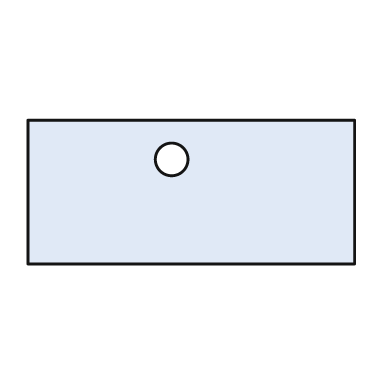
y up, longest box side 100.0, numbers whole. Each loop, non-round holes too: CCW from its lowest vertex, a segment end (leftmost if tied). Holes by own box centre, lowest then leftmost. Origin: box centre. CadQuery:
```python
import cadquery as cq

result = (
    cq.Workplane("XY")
    .moveTo(-50.0, -22.0)
    .lineTo(50.0, -22.0)
    .lineTo(50.0, 22.0)
    .lineTo(-50.0, 22.0)
    .close()
    .moveTo(-6.0, 10.0)
    .circle(5.0)
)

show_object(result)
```